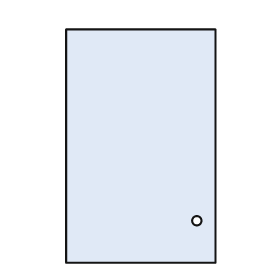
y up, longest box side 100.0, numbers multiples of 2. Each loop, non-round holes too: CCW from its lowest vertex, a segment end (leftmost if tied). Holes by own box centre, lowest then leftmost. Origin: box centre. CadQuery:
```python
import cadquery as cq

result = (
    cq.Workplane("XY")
    .moveTo(-32.0, -50.0)
    .lineTo(32.0, -50.0)
    .lineTo(32.0, 50.0)
    .lineTo(-32.0, 50.0)
    .close()
    .moveTo(24.0, -32.0)
    .circle(2.0)
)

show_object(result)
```